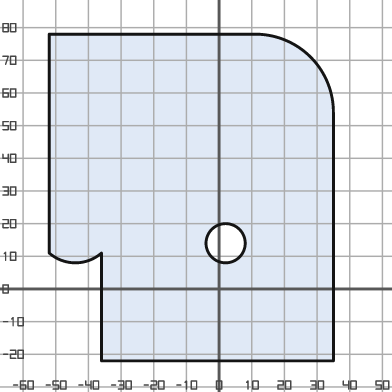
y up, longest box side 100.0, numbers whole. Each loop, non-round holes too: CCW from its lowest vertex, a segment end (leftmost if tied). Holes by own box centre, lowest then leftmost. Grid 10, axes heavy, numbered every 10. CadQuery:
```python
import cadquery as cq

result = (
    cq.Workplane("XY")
    .moveTo(-36.0, -22.0)
    .lineTo(35.0, -22.0)
    .lineTo(35.0, 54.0)
    .threePointArc((28.0, 71.0), (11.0, 78.0))
    .lineTo(-52.0, 78.0)
    .lineTo(-52.0, 11.0)
    .threePointArc((-44.0, 8.0), (-36.0, 11.0))
    .close()
    .moveTo(2.0, 14.0)
    .circle(6.0)
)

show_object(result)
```